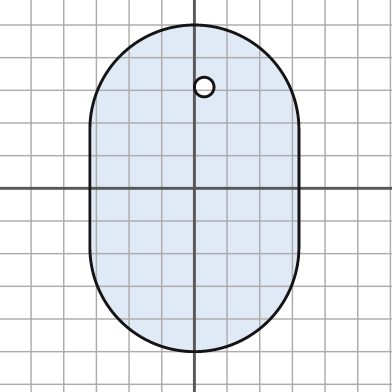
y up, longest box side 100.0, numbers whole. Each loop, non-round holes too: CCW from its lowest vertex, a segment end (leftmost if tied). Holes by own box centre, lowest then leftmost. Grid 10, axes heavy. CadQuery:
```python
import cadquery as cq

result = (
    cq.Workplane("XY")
    .moveTo(-32.0, -18.0)
    .threePointArc((0.0, -50.0), (32.0, -18.0))
    .lineTo(32.0, 18.0)
    .threePointArc((0.0, 50.0), (-32.0, 18.0))
    .close()
    .moveTo(3.0, 31.0)
    .circle(3.0)
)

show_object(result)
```